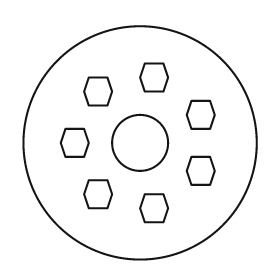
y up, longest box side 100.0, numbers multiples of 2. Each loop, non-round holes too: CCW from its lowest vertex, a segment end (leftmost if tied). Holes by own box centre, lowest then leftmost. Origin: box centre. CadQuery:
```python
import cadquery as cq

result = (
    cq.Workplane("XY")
    .moveTo(0.0, 0.0)
    .circle(50.0)
    .moveTo(2.0, -34.0)
    .lineTo(10.0, -34.0)
    .lineTo(12.0, -28.0)
    .lineTo(10.0, -22.0)
    .lineTo(2.0, -22.0)
    .lineTo(0.0, -28.0)
    .close()
    .moveTo(-22.0, -28.0)
    .lineTo(-14.0, -28.0)
    .lineTo(-12.0, -22.0)
    .lineTo(-14.0, -16.0)
    .lineTo(-22.0, -16.0)
    .lineTo(-24.0, -22.0)
    .close()
    .moveTo(22.0, -18.0)
    .lineTo(30.0, -18.0)
    .lineTo(32.0, -12.0)
    .lineTo(30.0, -6.0)
    .lineTo(22.0, -6.0)
    .lineTo(20.0, -12.0)
    .close()
    .moveTo(-32.0, -6.0)
    .lineTo(-24.0, -6.0)
    .lineTo(-22.0, 0.0)
    .lineTo(-24.0, 6.0)
    .lineTo(-32.0, 6.0)
    .lineTo(-34.0, 0.0)
    .close()
    .moveTo(0.0, 0.0)
    .circle(12.0)
    .moveTo(22.0, 6.0)
    .lineTo(30.0, 6.0)
    .lineTo(32.0, 12.0)
    .lineTo(30.0, 18.0)
    .lineTo(22.0, 18.0)
    .lineTo(20.0, 12.0)
    .close()
    .moveTo(-22.0, 16.0)
    .lineTo(-14.0, 16.0)
    .lineTo(-12.0, 22.0)
    .lineTo(-14.0, 28.0)
    .lineTo(-22.0, 28.0)
    .lineTo(-24.0, 22.0)
    .close()
    .moveTo(2.0, 22.0)
    .lineTo(10.0, 22.0)
    .lineTo(12.0, 28.0)
    .lineTo(10.0, 34.0)
    .lineTo(2.0, 34.0)
    .lineTo(0.0, 28.0)
    .close()
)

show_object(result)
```